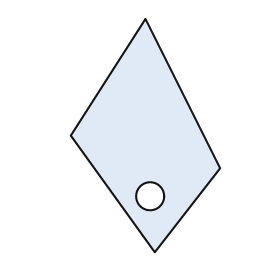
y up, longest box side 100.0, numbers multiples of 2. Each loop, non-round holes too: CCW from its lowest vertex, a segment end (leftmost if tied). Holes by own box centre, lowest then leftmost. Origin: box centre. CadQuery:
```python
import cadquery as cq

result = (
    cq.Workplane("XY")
    .moveTo(4.0, -50.0)
    .lineTo(32.0, -14.0)
    .lineTo(0.0, 50.0)
    .lineTo(-32.0, 0.0)
    .close()
    .moveTo(2.0, -26.0)
    .circle(6.0)
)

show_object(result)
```